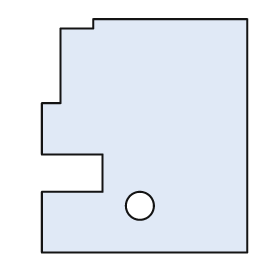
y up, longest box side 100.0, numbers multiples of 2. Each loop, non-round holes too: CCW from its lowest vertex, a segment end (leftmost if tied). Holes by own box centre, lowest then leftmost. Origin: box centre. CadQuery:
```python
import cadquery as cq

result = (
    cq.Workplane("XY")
    .moveTo(-44.0, -50.0)
    .lineTo(44.0, -50.0)
    .lineTo(44.0, 50.0)
    .lineTo(-22.0, 50.0)
    .lineTo(-22.0, 46.0)
    .lineTo(-36.0, 46.0)
    .lineTo(-36.0, 14.0)
    .lineTo(-44.0, 14.0)
    .lineTo(-44.0, -8.0)
    .lineTo(-18.0, -8.0)
    .lineTo(-18.0, -24.0)
    .lineTo(-44.0, -24.0)
    .close()
    .moveTo(-2.0, -30.0)
    .circle(6.0)
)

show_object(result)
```